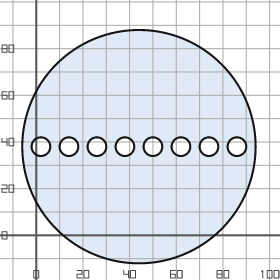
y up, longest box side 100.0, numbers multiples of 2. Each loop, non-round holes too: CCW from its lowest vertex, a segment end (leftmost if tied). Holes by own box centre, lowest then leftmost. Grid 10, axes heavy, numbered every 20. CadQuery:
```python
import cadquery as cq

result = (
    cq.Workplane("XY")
    .moveTo(44.0, 38.0)
    .circle(50.0)
    .moveTo(2.0, 38.0)
    .circle(4.0)
    .moveTo(14.0, 38.0)
    .circle(4.0)
    .moveTo(26.0, 38.0)
    .circle(4.0)
    .moveTo(38.0, 38.0)
    .circle(4.0)
    .moveTo(50.0, 38.0)
    .circle(4.0)
    .moveTo(62.0, 38.0)
    .circle(4.0)
    .moveTo(74.0, 38.0)
    .circle(4.0)
    .moveTo(86.0, 38.0)
    .circle(4.0)
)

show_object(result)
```